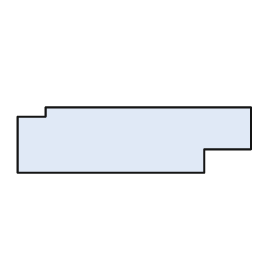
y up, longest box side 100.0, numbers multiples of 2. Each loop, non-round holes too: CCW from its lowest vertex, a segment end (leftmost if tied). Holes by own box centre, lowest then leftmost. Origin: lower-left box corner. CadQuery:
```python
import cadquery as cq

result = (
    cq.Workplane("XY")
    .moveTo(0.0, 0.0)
    .lineTo(80.0, 0.0)
    .lineTo(80.0, 10.0)
    .lineTo(100.0, 10.0)
    .lineTo(100.0, 28.0)
    .lineTo(12.0, 28.0)
    .lineTo(12.0, 24.0)
    .lineTo(0.0, 24.0)
    .close()
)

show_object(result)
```